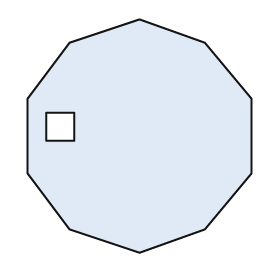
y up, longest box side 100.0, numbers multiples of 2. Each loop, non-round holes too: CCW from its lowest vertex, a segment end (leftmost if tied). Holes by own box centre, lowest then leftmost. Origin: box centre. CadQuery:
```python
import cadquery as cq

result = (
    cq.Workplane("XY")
    .moveTo(0.0, -50.0)
    .lineTo(28.0, -40.0)
    .lineTo(48.0, -16.0)
    .lineTo(48.0, 16.0)
    .lineTo(28.0, 40.0)
    .lineTo(0.0, 50.0)
    .lineTo(-30.0, 40.0)
    .lineTo(-48.0, 16.0)
    .lineTo(-48.0, -16.0)
    .lineTo(-30.0, -40.0)
    .close()
    .moveTo(-40.0, -2.0)
    .lineTo(-28.0, -2.0)
    .lineTo(-28.0, 10.0)
    .lineTo(-40.0, 10.0)
    .close()
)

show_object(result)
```